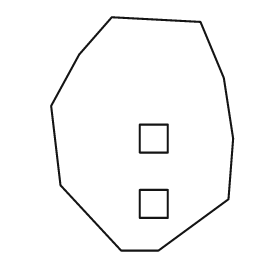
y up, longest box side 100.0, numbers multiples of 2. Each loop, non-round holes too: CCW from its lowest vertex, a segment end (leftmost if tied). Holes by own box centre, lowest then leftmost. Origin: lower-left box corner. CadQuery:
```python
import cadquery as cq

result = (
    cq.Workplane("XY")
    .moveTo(30.0, 0.0)
    .lineTo(46.0, 0.0)
    .lineTo(76.0, 22.0)
    .lineTo(78.0, 48.0)
    .lineTo(74.0, 74.0)
    .lineTo(64.0, 98.0)
    .lineTo(26.0, 100.0)
    .lineTo(12.0, 84.0)
    .lineTo(0.0, 62.0)
    .lineTo(4.0, 28.0)
    .close()
    .moveTo(38.0, 14.0)
    .lineTo(50.0, 14.0)
    .lineTo(50.0, 26.0)
    .lineTo(38.0, 26.0)
    .close()
    .moveTo(38.0, 42.0)
    .lineTo(50.0, 42.0)
    .lineTo(50.0, 54.0)
    .lineTo(38.0, 54.0)
    .close()
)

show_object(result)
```